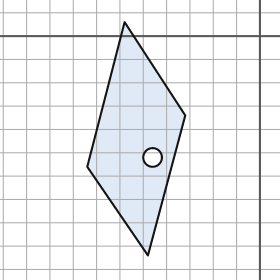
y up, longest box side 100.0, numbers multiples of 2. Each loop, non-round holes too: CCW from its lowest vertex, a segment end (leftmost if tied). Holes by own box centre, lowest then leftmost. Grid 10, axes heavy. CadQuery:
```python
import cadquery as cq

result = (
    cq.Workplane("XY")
    .moveTo(-48.0, -94.0)
    .lineTo(-32.0, -34.0)
    .lineTo(-58.0, 6.0)
    .lineTo(-74.0, -56.0)
    .close()
    .moveTo(-46.0, -52.0)
    .circle(4.0)
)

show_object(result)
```